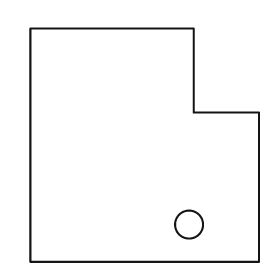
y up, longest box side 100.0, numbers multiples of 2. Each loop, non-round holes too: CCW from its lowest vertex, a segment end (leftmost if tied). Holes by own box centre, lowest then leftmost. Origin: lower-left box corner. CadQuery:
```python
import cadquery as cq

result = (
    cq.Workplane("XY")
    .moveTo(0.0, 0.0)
    .lineTo(98.0, 0.0)
    .lineTo(98.0, 64.0)
    .lineTo(70.0, 64.0)
    .lineTo(70.0, 100.0)
    .lineTo(0.0, 100.0)
    .close()
    .moveTo(68.0, 16.0)
    .circle(6.0)
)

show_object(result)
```